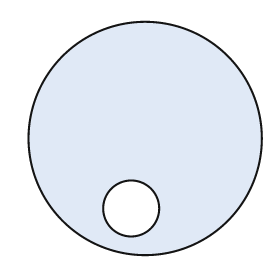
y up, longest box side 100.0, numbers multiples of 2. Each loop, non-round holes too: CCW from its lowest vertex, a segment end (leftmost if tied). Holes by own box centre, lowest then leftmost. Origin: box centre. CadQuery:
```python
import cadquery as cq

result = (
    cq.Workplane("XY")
    .moveTo(0.0, 0.0)
    .circle(50.0)
    .moveTo(-6.0, -30.0)
    .circle(12.0)
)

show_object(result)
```